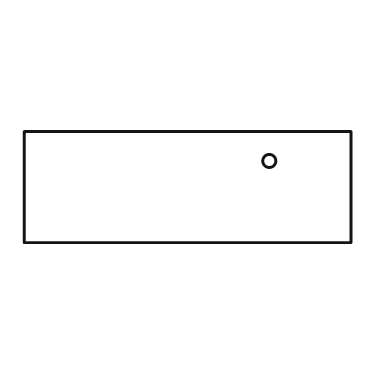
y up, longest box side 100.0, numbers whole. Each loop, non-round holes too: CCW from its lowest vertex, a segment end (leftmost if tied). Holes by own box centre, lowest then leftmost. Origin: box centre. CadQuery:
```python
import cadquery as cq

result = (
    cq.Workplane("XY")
    .moveTo(-50.0, -17.0)
    .lineTo(50.0, -17.0)
    .lineTo(50.0, 17.0)
    .lineTo(-50.0, 17.0)
    .close()
    .moveTo(25.0, 8.0)
    .circle(2.0)
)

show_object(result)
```